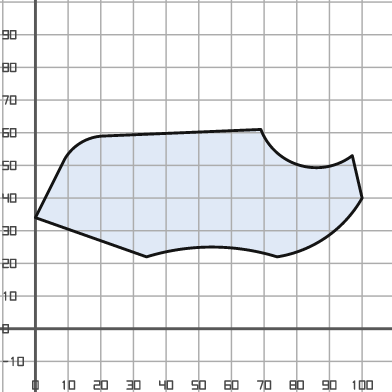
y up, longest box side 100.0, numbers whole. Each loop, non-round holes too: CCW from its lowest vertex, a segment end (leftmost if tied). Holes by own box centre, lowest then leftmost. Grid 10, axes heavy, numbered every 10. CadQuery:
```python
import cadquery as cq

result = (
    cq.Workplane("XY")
    .moveTo(34.0, 22.0)
    .threePointArc((54.0, 25.0), (74.0, 22.0))
    .threePointArc((89.0, 28.0), (100.0, 40.0))
    .lineTo(97.0, 53.0)
    .threePointArc((81.0, 50.0), (69.0, 61.0))
    .lineTo(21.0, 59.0)
    .threePointArc((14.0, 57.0), (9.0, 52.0))
    .lineTo(0.0, 34.0)
    .close()
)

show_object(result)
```